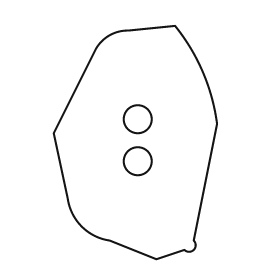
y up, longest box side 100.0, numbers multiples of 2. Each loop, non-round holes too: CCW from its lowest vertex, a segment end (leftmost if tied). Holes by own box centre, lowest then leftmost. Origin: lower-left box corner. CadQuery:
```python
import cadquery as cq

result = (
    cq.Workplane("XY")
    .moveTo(44.0, 0.0)
    .lineTo(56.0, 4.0)
    .threePointArc((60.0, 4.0), (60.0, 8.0))
    .lineTo(70.0, 58.0)
    .threePointArc((64.0, 80.0), (52.0, 100.0))
    .lineTo(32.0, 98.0)
    .threePointArc((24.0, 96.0), (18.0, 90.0))
    .lineTo(0.0, 54.0)
    .lineTo(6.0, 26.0)
    .threePointArc((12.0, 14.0), (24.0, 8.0))
    .close()
    .moveTo(36.0, 42.0)
    .circle(6.0)
    .moveTo(36.0, 60.0)
    .circle(6.0)
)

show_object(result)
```